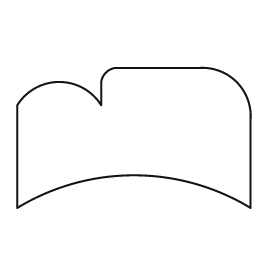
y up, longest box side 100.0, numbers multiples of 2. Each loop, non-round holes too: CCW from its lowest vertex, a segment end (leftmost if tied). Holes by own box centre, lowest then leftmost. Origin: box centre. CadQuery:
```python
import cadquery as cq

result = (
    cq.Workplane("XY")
    .moveTo(-50.0, -30.0)
    .threePointArc((0.0, -16.0), (50.0, -30.0))
    .lineTo(50.0, 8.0)
    .threePointArc((44.0, 24.0), (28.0, 30.0))
    .lineTo(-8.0, 30.0)
    .threePointArc((-12.0, 28.0), (-14.0, 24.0))
    .lineTo(-14.0, 14.0)
    .threePointArc((-32.0, 24.0), (-50.0, 14.0))
    .close()
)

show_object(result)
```